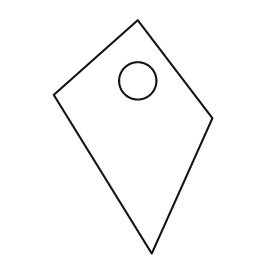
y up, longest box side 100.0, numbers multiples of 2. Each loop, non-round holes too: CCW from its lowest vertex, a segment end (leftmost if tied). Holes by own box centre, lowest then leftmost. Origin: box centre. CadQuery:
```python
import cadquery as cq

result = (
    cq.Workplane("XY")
    .moveTo(8.0, -50.0)
    .lineTo(34.0, 8.0)
    .lineTo(2.0, 50.0)
    .lineTo(-34.0, 18.0)
    .close()
    .moveTo(2.0, 24.0)
    .circle(8.0)
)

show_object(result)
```